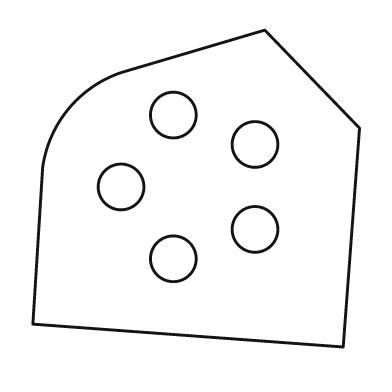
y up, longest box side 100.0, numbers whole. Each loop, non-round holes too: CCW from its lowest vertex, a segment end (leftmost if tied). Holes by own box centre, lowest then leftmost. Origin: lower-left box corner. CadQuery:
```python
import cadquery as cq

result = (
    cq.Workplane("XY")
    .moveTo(95.0, 0.0)
    .lineTo(100.0, 67.0)
    .lineTo(71.0, 97.0)
    .lineTo(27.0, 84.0)
    .threePointArc((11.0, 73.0), (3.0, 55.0))
    .lineTo(0.0, 7.0)
    .close()
    .moveTo(43.0, 27.0)
    .circle(7.0)
    .moveTo(68.0, 36.0)
    .circle(7.0)
    .moveTo(27.0, 49.0)
    .circle(7.0)
    .moveTo(68.0, 62.0)
    .circle(7.0)
    .moveTo(43.0, 71.0)
    .circle(7.0)
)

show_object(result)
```